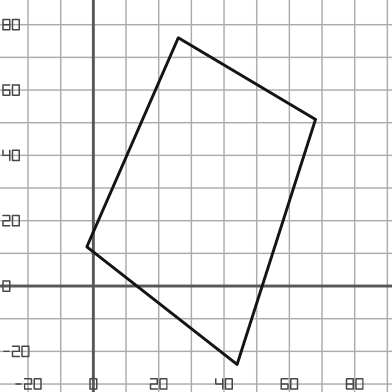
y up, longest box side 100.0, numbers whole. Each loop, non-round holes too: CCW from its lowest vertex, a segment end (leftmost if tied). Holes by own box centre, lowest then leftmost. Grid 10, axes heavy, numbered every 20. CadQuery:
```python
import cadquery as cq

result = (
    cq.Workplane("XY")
    .moveTo(44.0, -24.0)
    .lineTo(68.0, 51.0)
    .lineTo(26.0, 76.0)
    .lineTo(-2.0, 12.0)
    .close()
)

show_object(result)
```